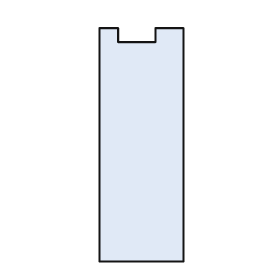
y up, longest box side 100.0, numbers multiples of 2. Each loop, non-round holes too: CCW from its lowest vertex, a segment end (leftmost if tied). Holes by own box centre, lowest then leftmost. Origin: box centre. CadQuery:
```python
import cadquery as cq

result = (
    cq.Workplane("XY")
    .moveTo(-18.0, -50.0)
    .lineTo(18.0, -50.0)
    .lineTo(18.0, 50.0)
    .lineTo(6.0, 50.0)
    .lineTo(6.0, 44.0)
    .lineTo(-10.0, 44.0)
    .lineTo(-10.0, 50.0)
    .lineTo(-18.0, 50.0)
    .close()
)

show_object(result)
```